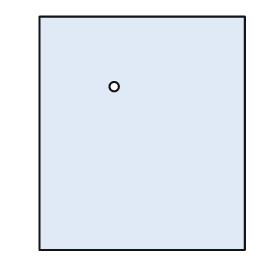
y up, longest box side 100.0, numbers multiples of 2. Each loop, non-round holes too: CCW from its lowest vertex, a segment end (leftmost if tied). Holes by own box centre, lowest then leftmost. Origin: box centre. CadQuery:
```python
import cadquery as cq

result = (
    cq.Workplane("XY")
    .moveTo(-44.0, -50.0)
    .lineTo(44.0, -50.0)
    .lineTo(44.0, 50.0)
    .lineTo(-44.0, 50.0)
    .close()
    .moveTo(-12.0, 20.0)
    .circle(2.0)
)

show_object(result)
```